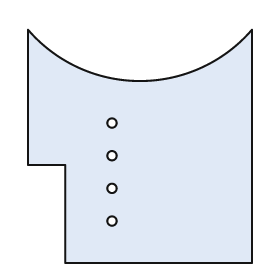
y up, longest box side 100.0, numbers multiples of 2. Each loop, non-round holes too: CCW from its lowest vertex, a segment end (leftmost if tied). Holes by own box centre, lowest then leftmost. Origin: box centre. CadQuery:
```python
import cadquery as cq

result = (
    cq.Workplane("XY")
    .moveTo(-32.0, -50.0)
    .lineTo(48.0, -50.0)
    .lineTo(48.0, 50.0)
    .threePointArc((0.0, 28.0), (-48.0, 50.0))
    .lineTo(-48.0, -8.0)
    .lineTo(-32.0, -8.0)
    .close()
    .moveTo(-12.0, -32.0)
    .circle(2.0)
    .moveTo(-12.0, -18.0)
    .circle(2.0)
    .moveTo(-12.0, -4.0)
    .circle(2.0)
    .moveTo(-12.0, 10.0)
    .circle(2.0)
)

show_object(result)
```